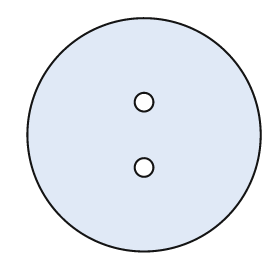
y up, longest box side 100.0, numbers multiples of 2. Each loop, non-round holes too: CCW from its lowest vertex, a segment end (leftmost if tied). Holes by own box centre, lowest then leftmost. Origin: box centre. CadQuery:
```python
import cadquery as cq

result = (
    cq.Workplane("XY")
    .moveTo(0.0, 0.0)
    .circle(50.0)
    .moveTo(0.0, -14.0)
    .circle(4.0)
    .moveTo(0.0, 14.0)
    .circle(4.0)
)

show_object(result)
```